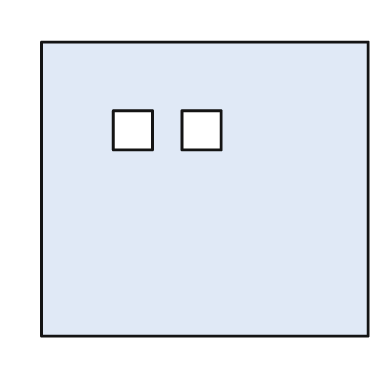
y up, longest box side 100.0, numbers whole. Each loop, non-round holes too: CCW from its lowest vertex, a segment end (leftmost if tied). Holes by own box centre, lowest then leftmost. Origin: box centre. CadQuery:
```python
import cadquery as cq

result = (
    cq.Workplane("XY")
    .moveTo(-50.0, -45.0)
    .lineTo(50.0, -45.0)
    .lineTo(50.0, 45.0)
    .lineTo(-50.0, 45.0)
    .close()
    .moveTo(-28.0, 12.0)
    .lineTo(-16.0, 12.0)
    .lineTo(-16.0, 24.0)
    .lineTo(-28.0, 24.0)
    .close()
    .moveTo(-7.0, 12.0)
    .lineTo(5.0, 12.0)
    .lineTo(5.0, 24.0)
    .lineTo(-7.0, 24.0)
    .close()
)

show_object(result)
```